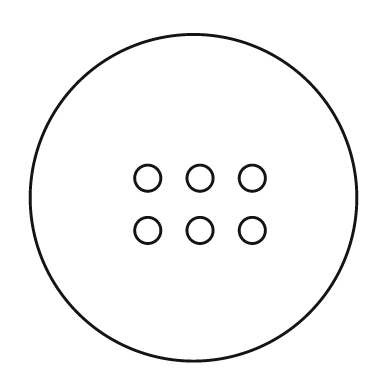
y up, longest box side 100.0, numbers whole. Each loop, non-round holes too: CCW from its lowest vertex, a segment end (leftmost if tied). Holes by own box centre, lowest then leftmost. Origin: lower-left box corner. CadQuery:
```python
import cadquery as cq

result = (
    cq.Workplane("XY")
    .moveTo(50.0, 50.0)
    .circle(50.0)
    .moveTo(36.0, 40.0)
    .circle(4.0)
    .moveTo(52.0, 40.0)
    .circle(4.0)
    .moveTo(68.0, 40.0)
    .circle(4.0)
    .moveTo(36.0, 56.0)
    .circle(4.0)
    .moveTo(52.0, 56.0)
    .circle(4.0)
    .moveTo(68.0, 56.0)
    .circle(4.0)
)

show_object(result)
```